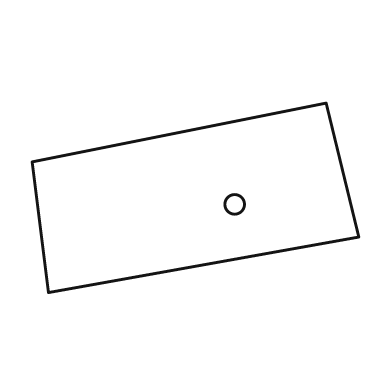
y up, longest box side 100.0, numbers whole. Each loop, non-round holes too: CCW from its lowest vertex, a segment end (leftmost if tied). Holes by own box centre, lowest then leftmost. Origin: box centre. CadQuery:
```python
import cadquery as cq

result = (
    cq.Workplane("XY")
    .moveTo(-45.0, -29.0)
    .lineTo(50.0, -12.0)
    .lineTo(40.0, 29.0)
    .lineTo(-50.0, 11.0)
    .close()
    .moveTo(12.0, -2.0)
    .circle(3.0)
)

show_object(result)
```